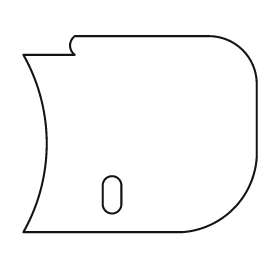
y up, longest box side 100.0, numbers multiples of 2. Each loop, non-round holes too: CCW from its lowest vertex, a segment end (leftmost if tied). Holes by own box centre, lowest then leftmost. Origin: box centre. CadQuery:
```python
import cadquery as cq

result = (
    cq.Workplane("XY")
    .moveTo(-50.0, -42.0)
    .lineTo(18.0, -42.0)
    .threePointArc((40.0, -32.0), (50.0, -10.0))
    .lineTo(50.0, 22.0)
    .threePointArc((44.0, 36.0), (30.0, 42.0))
    .lineTo(-28.0, 42.0)
    .threePointArc((-30.0, 38.0), (-28.0, 34.0))
    .lineTo(-50.0, 34.0)
    .threePointArc((-40.0, -4.0), (-50.0, -42.0))
    .close()
    .moveTo(-16.0, -30.0)
    .threePointArc((-12.0, -34.0), (-8.0, -30.0))
    .lineTo(-8.0, -22.0)
    .threePointArc((-12.0, -18.0), (-16.0, -22.0))
    .close()
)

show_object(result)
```